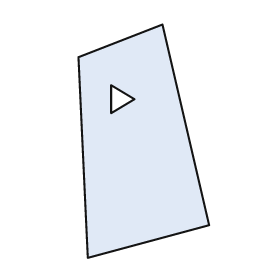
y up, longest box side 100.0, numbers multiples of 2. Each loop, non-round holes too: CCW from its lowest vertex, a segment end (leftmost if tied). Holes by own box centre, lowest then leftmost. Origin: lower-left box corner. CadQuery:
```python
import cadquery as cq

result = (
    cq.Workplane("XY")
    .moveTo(4.0, 0.0)
    .lineTo(56.0, 14.0)
    .lineTo(36.0, 100.0)
    .lineTo(0.0, 86.0)
    .close()
    .moveTo(14.0, 62.0)
    .lineTo(24.0, 68.0)
    .lineTo(14.0, 74.0)
    .close()
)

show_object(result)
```